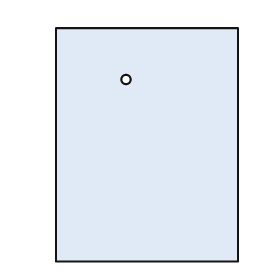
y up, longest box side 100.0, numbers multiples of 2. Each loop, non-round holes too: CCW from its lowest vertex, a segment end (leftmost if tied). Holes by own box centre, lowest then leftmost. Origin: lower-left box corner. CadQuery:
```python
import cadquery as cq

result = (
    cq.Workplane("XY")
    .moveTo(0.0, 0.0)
    .lineTo(78.0, 0.0)
    .lineTo(78.0, 100.0)
    .lineTo(0.0, 100.0)
    .close()
    .moveTo(30.0, 78.0)
    .circle(2.0)
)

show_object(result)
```